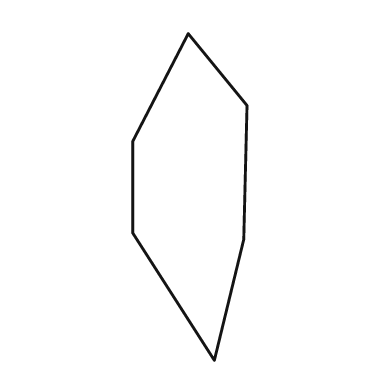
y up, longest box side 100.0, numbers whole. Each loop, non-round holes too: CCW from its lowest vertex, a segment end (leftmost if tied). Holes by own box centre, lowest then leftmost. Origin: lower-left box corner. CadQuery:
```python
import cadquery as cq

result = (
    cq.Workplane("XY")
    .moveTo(25.0, 0.0)
    .lineTo(34.0, 37.0)
    .lineTo(35.0, 78.0)
    .lineTo(17.0, 100.0)
    .lineTo(0.0, 67.0)
    .lineTo(0.0, 39.0)
    .close()
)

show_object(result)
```